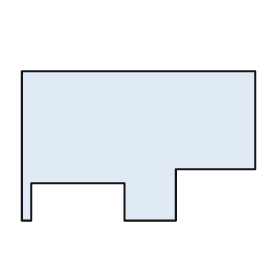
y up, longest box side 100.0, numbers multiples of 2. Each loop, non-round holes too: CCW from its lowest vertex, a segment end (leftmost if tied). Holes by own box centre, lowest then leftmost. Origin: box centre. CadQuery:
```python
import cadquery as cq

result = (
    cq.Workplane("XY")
    .moveTo(-50.0, -32.0)
    .lineTo(-46.0, -32.0)
    .lineTo(-46.0, -16.0)
    .lineTo(-6.0, -16.0)
    .lineTo(-6.0, -32.0)
    .lineTo(16.0, -32.0)
    .lineTo(16.0, -10.0)
    .lineTo(50.0, -10.0)
    .lineTo(50.0, 32.0)
    .lineTo(-50.0, 32.0)
    .close()
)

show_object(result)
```